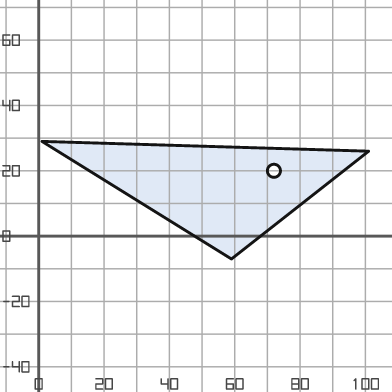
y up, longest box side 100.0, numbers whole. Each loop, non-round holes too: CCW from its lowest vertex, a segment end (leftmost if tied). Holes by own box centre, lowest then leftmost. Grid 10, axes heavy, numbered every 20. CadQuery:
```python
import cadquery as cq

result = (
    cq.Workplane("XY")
    .moveTo(59.0, -7.0)
    .lineTo(101.0, 26.0)
    .lineTo(1.0, 29.0)
    .close()
    .moveTo(72.0, 20.0)
    .circle(2.0)
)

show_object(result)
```